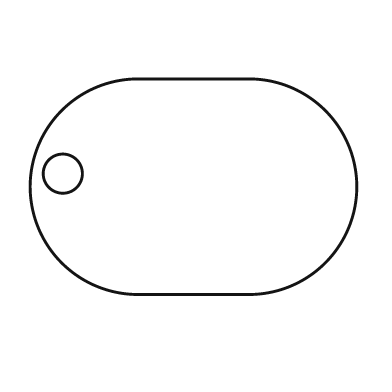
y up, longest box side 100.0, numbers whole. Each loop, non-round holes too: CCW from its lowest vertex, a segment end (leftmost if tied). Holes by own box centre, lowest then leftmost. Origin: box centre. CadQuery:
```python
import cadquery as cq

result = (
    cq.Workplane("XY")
    .moveTo(-17.0, -33.0)
    .lineTo(17.0, -33.0)
    .threePointArc((50.0, 0.0), (17.0, 33.0))
    .lineTo(-17.0, 33.0)
    .threePointArc((-50.0, 0.0), (-17.0, -33.0))
    .close()
    .moveTo(-40.0, 4.0)
    .circle(6.0)
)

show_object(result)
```